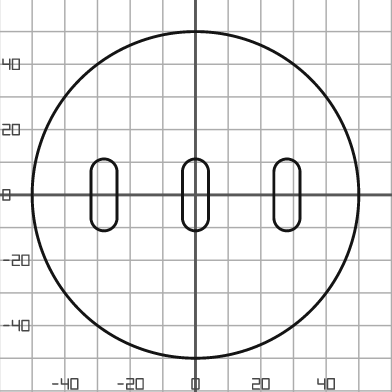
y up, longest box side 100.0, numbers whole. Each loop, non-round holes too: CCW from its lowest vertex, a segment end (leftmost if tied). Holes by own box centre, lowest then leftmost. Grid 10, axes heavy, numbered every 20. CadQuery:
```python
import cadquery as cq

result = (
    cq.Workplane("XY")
    .moveTo(0.0, 0.0)
    .circle(50.0)
    .moveTo(-32.0, -7.0)
    .threePointArc((-28.0, -11.0), (-24.0, -7.0))
    .lineTo(-24.0, 7.0)
    .threePointArc((-28.0, 11.0), (-32.0, 7.0))
    .close()
    .moveTo(-4.0, -7.0)
    .threePointArc((0.0, -11.0), (4.0, -7.0))
    .lineTo(4.0, 7.0)
    .threePointArc((0.0, 11.0), (-4.0, 7.0))
    .close()
    .moveTo(24.0, -7.0)
    .threePointArc((28.0, -11.0), (32.0, -7.0))
    .lineTo(32.0, 7.0)
    .threePointArc((28.0, 11.0), (24.0, 7.0))
    .close()
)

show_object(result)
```